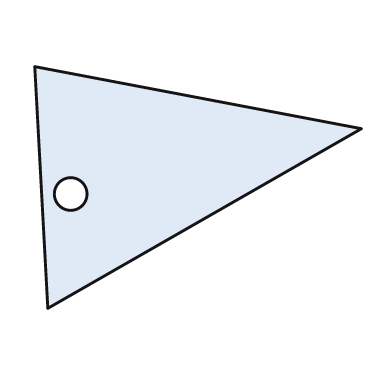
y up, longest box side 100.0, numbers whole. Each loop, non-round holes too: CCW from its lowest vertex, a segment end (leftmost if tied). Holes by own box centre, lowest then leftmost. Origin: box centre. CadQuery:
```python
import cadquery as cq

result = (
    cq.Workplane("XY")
    .moveTo(-46.0, -37.0)
    .lineTo(50.0, 18.0)
    .lineTo(-50.0, 37.0)
    .close()
    .moveTo(-39.0, -2.0)
    .circle(5.0)
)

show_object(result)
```